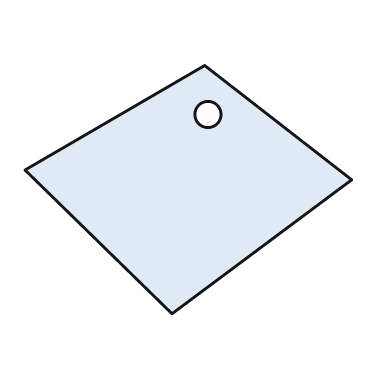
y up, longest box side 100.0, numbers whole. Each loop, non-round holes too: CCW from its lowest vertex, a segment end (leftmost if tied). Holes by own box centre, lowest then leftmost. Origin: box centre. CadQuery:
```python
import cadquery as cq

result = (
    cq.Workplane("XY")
    .moveTo(-5.0, -38.0)
    .lineTo(50.0, 3.0)
    .lineTo(5.0, 38.0)
    .lineTo(-50.0, 6.0)
    .close()
    .moveTo(6.0, 23.0)
    .circle(4.0)
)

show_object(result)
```